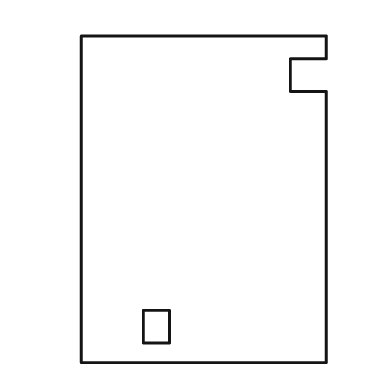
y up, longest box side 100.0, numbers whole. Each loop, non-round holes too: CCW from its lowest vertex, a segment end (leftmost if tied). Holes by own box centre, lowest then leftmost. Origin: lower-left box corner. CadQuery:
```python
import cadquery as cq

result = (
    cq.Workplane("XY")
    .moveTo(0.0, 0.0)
    .lineTo(75.0, 0.0)
    .lineTo(75.0, 83.0)
    .lineTo(64.0, 83.0)
    .lineTo(64.0, 93.0)
    .lineTo(75.0, 93.0)
    .lineTo(75.0, 100.0)
    .lineTo(0.0, 100.0)
    .close()
    .moveTo(19.0, 6.0)
    .lineTo(27.0, 6.0)
    .lineTo(27.0, 16.0)
    .lineTo(19.0, 16.0)
    .close()
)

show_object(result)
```